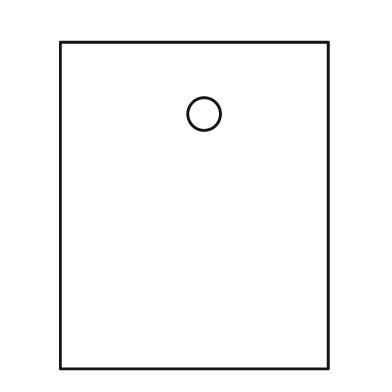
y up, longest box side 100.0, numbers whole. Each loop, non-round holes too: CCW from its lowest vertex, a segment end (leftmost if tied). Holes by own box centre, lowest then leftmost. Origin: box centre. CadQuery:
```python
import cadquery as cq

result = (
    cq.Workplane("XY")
    .moveTo(-41.0, -50.0)
    .lineTo(41.0, -50.0)
    .lineTo(41.0, 50.0)
    .lineTo(-41.0, 50.0)
    .close()
    .moveTo(3.0, 28.0)
    .circle(5.0)
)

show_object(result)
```